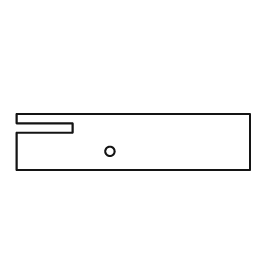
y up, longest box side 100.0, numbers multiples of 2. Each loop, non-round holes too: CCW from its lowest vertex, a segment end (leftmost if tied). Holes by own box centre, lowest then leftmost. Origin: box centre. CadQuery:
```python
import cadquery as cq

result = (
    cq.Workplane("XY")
    .moveTo(-50.0, -12.0)
    .lineTo(50.0, -12.0)
    .lineTo(50.0, 12.0)
    .lineTo(-50.0, 12.0)
    .lineTo(-50.0, 8.0)
    .lineTo(-26.0, 8.0)
    .lineTo(-26.0, 4.0)
    .lineTo(-50.0, 4.0)
    .close()
    .moveTo(-10.0, -4.0)
    .circle(2.0)
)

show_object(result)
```